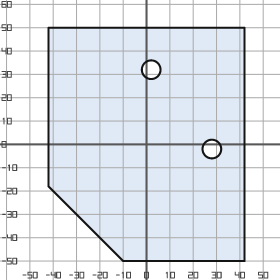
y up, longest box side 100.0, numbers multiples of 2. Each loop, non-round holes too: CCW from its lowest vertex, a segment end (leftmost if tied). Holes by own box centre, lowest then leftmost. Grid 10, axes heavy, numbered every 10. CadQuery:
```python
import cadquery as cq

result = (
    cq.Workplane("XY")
    .moveTo(-10.0, -50.0)
    .lineTo(42.0, -50.0)
    .lineTo(42.0, 50.0)
    .lineTo(-42.0, 50.0)
    .lineTo(-42.0, -18.0)
    .close()
    .moveTo(28.0, -2.0)
    .circle(4.0)
    .moveTo(2.0, 32.0)
    .circle(4.0)
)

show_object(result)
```